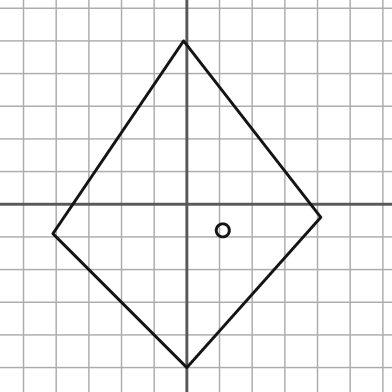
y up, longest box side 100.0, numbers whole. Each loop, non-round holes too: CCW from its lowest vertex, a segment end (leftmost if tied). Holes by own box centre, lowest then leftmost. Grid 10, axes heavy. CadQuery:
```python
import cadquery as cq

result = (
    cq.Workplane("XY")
    .moveTo(0.0, -50.0)
    .lineTo(41.0, -4.0)
    .lineTo(-1.0, 50.0)
    .lineTo(-41.0, -9.0)
    .close()
    .moveTo(11.0, -8.0)
    .circle(2.0)
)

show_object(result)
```